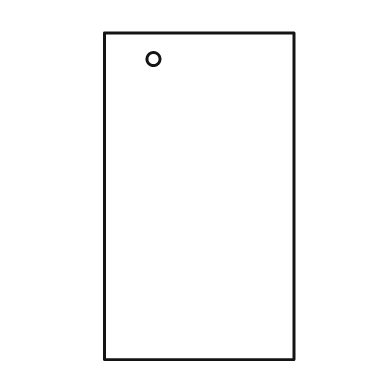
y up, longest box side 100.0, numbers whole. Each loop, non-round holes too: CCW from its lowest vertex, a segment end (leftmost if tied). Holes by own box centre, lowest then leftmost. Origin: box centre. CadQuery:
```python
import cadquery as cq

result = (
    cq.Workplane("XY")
    .moveTo(-29.0, -50.0)
    .lineTo(29.0, -50.0)
    .lineTo(29.0, 50.0)
    .lineTo(-29.0, 50.0)
    .close()
    .moveTo(-14.0, 42.0)
    .circle(2.0)
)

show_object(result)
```